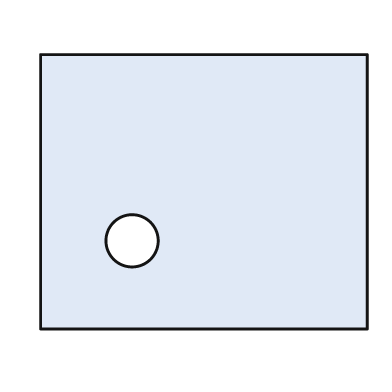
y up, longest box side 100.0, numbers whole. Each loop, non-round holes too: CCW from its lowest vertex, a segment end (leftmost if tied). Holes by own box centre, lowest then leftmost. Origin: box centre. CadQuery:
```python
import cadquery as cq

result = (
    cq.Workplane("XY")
    .moveTo(-50.0, -42.0)
    .lineTo(50.0, -42.0)
    .lineTo(50.0, 42.0)
    .lineTo(-50.0, 42.0)
    .close()
    .moveTo(-22.0, -15.0)
    .circle(8.0)
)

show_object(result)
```